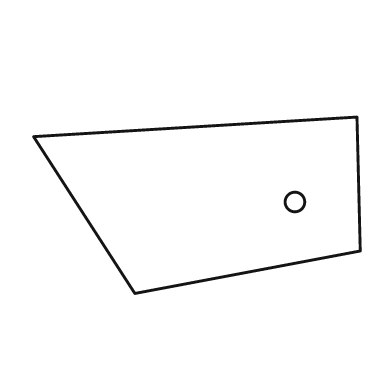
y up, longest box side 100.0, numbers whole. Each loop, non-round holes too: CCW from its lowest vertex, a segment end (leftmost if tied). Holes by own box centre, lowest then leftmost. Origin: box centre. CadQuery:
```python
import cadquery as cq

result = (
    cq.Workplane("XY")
    .moveTo(-19.0, -27.0)
    .lineTo(50.0, -14.0)
    .lineTo(49.0, 27.0)
    .lineTo(-50.0, 21.0)
    .close()
    .moveTo(30.0, 1.0)
    .circle(3.0)
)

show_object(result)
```